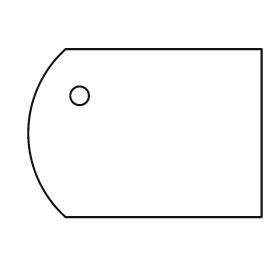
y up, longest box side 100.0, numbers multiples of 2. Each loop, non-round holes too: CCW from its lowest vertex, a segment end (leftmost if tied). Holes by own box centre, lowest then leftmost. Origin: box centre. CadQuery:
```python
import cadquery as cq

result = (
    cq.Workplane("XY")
    .moveTo(-34.0, -36.0)
    .lineTo(50.0, -36.0)
    .lineTo(50.0, 36.0)
    .lineTo(-34.0, 36.0)
    .threePointArc((-50.0, 0.0), (-34.0, -36.0))
    .close()
    .moveTo(-28.0, 16.0)
    .circle(4.0)
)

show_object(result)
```